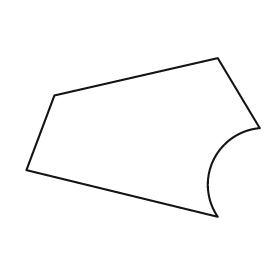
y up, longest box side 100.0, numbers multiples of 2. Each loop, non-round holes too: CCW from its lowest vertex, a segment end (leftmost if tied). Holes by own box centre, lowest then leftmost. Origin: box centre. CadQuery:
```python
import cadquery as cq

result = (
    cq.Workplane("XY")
    .moveTo(32.0, -34.0)
    .threePointArc((30.0, -10.0), (50.0, 4.0))
    .lineTo(32.0, 34.0)
    .lineTo(-38.0, 18.0)
    .lineTo(-50.0, -14.0)
    .close()
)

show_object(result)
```